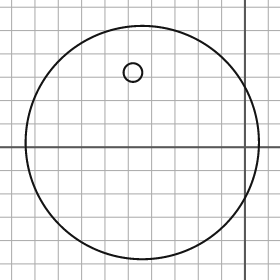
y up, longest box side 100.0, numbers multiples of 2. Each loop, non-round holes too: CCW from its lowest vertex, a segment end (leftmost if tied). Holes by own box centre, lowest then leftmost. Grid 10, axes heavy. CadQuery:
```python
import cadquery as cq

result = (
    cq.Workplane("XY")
    .moveTo(-44.0, 2.0)
    .circle(50.0)
    .moveTo(-48.0, 32.0)
    .circle(4.0)
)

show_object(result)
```